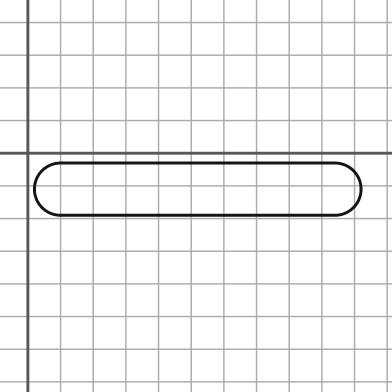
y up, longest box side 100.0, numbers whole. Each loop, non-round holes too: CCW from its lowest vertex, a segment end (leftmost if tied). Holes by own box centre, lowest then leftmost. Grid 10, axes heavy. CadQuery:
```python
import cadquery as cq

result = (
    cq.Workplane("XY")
    .moveTo(10.0, -19.0)
    .lineTo(94.0, -19.0)
    .threePointArc((102.0, -11.0), (94.0, -3.0))
    .lineTo(10.0, -3.0)
    .threePointArc((2.0, -11.0), (10.0, -19.0))
    .close()
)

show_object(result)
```